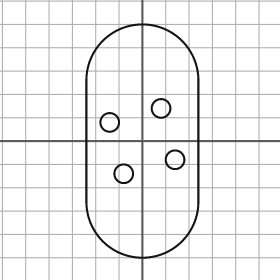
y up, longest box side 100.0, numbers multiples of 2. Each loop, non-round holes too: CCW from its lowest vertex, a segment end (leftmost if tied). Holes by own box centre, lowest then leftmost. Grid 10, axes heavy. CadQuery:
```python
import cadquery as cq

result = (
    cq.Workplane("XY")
    .moveTo(-24.0, -26.0)
    .threePointArc((0.0, -50.0), (24.0, -26.0))
    .lineTo(24.0, 26.0)
    .threePointArc((0.0, 50.0), (-24.0, 26.0))
    .close()
    .moveTo(-8.0, -14.0)
    .circle(4.0)
    .moveTo(14.0, -8.0)
    .circle(4.0)
    .moveTo(-14.0, 8.0)
    .circle(4.0)
    .moveTo(8.0, 14.0)
    .circle(4.0)
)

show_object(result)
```